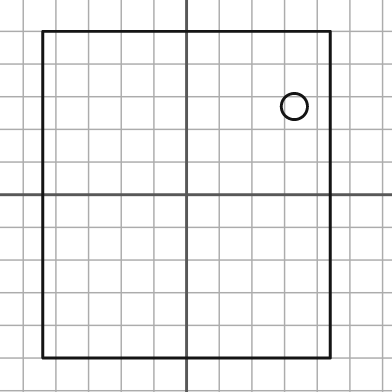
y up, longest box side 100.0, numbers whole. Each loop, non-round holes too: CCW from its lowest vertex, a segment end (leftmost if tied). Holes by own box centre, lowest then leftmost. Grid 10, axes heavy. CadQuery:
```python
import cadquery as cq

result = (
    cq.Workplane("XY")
    .moveTo(-44.0, -50.0)
    .lineTo(44.0, -50.0)
    .lineTo(44.0, 50.0)
    .lineTo(-44.0, 50.0)
    .close()
    .moveTo(33.0, 27.0)
    .circle(4.0)
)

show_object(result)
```